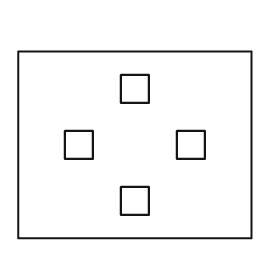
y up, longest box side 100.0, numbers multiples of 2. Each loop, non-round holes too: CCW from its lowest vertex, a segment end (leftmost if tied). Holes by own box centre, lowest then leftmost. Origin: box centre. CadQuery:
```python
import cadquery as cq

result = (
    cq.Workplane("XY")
    .moveTo(-50.0, -40.0)
    .lineTo(50.0, -40.0)
    .lineTo(50.0, 40.0)
    .lineTo(-50.0, 40.0)
    .close()
    .moveTo(-6.0, -30.0)
    .lineTo(6.0, -30.0)
    .lineTo(6.0, -18.0)
    .lineTo(-6.0, -18.0)
    .close()
    .moveTo(-30.0, -6.0)
    .lineTo(-18.0, -6.0)
    .lineTo(-18.0, 6.0)
    .lineTo(-30.0, 6.0)
    .close()
    .moveTo(18.0, -6.0)
    .lineTo(30.0, -6.0)
    .lineTo(30.0, 6.0)
    .lineTo(18.0, 6.0)
    .close()
    .moveTo(-6.0, 18.0)
    .lineTo(6.0, 18.0)
    .lineTo(6.0, 30.0)
    .lineTo(-6.0, 30.0)
    .close()
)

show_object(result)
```